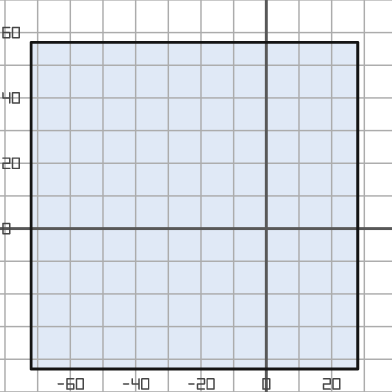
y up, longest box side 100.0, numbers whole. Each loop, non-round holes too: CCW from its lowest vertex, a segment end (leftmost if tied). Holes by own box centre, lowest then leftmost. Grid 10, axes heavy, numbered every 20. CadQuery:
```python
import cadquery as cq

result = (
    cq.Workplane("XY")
    .moveTo(-72.0, -43.0)
    .lineTo(28.0, -43.0)
    .lineTo(28.0, 57.0)
    .lineTo(-72.0, 57.0)
    .close()
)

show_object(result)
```